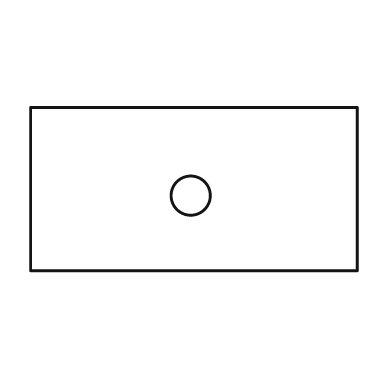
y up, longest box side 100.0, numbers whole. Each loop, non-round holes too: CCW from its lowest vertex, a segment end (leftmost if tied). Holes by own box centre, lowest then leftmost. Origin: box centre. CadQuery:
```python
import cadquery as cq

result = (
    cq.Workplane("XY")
    .moveTo(-50.0, -25.0)
    .lineTo(50.0, -25.0)
    .lineTo(50.0, 25.0)
    .lineTo(-50.0, 25.0)
    .close()
    .moveTo(-1.0, -2.0)
    .circle(6.0)
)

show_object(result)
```